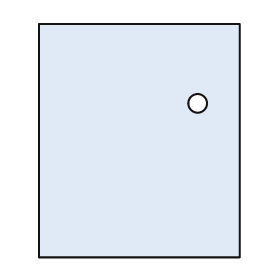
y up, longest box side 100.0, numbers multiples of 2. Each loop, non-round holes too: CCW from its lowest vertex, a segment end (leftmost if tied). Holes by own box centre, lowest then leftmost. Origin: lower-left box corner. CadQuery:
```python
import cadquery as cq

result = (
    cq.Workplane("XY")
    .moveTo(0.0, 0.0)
    .lineTo(86.0, 0.0)
    .lineTo(86.0, 100.0)
    .lineTo(0.0, 100.0)
    .close()
    .moveTo(68.0, 66.0)
    .circle(4.0)
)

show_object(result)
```